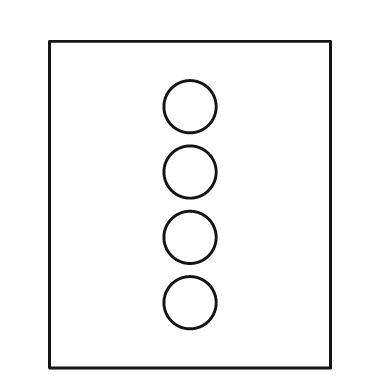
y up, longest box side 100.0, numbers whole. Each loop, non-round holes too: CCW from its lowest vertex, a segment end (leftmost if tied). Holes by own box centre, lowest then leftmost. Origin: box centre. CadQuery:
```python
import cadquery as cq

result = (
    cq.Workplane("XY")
    .moveTo(-43.0, -50.0)
    .lineTo(43.0, -50.0)
    .lineTo(43.0, 50.0)
    .lineTo(-43.0, 50.0)
    .close()
    .moveTo(0.0, -30.0)
    .circle(8.0)
    .moveTo(0.0, -10.0)
    .circle(8.0)
    .moveTo(0.0, 10.0)
    .circle(8.0)
    .moveTo(0.0, 30.0)
    .circle(8.0)
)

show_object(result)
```